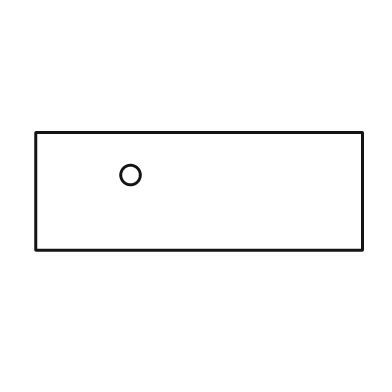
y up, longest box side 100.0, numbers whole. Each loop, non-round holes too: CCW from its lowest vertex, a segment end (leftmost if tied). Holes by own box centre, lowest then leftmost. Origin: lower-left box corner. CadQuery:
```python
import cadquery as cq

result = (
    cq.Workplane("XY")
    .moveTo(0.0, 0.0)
    .lineTo(100.0, 0.0)
    .lineTo(100.0, 36.0)
    .lineTo(0.0, 36.0)
    .close()
    .moveTo(29.0, 23.0)
    .circle(3.0)
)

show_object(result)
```